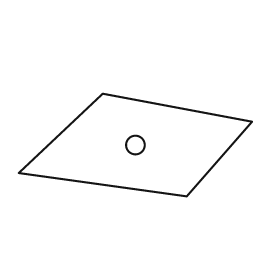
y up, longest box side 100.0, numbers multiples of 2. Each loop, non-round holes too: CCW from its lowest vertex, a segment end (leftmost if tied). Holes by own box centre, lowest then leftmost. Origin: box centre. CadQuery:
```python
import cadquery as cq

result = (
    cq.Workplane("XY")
    .moveTo(22.0, -22.0)
    .lineTo(50.0, 10.0)
    .lineTo(-14.0, 22.0)
    .lineTo(-50.0, -12.0)
    .close()
    .moveTo(0.0, 0.0)
    .circle(4.0)
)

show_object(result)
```